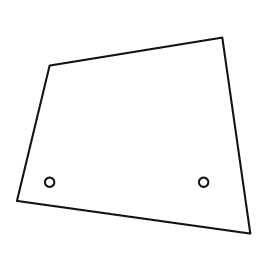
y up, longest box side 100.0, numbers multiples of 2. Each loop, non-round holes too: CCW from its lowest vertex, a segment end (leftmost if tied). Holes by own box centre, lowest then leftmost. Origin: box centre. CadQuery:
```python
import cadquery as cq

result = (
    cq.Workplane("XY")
    .moveTo(50.0, -42.0)
    .lineTo(38.0, 42.0)
    .lineTo(-36.0, 30.0)
    .lineTo(-50.0, -28.0)
    .close()
    .moveTo(-36.0, -20.0)
    .circle(2.0)
    .moveTo(30.0, -20.0)
    .circle(2.0)
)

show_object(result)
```